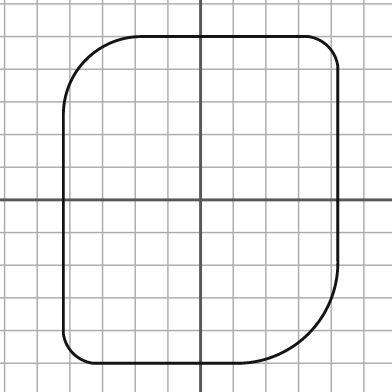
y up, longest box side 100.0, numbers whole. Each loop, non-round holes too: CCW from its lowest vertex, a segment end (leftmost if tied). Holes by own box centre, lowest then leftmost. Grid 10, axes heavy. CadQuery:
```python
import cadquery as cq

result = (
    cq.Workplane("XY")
    .moveTo(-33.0, -50.0)
    .lineTo(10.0, -50.0)
    .threePointArc((33.0, -41.0), (42.0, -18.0))
    .lineTo(42.0, 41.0)
    .threePointArc((39.0, 47.0), (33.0, 50.0))
    .lineTo(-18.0, 50.0)
    .threePointArc((-35.0, 43.0), (-42.0, 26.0))
    .lineTo(-42.0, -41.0)
    .threePointArc((-39.0, -47.0), (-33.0, -50.0))
    .close()
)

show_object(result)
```